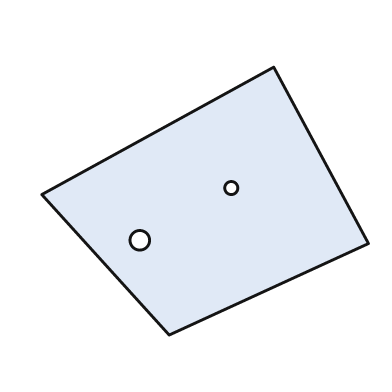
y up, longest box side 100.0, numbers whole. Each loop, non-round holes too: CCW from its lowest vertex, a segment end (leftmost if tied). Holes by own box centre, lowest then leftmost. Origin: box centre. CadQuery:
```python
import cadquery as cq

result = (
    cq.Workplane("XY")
    .moveTo(-11.0, -41.0)
    .lineTo(50.0, -13.0)
    .lineTo(21.0, 41.0)
    .lineTo(-50.0, 2.0)
    .close()
    .moveTo(-20.0, -12.0)
    .circle(3.0)
    .moveTo(8.0, 4.0)
    .circle(2.0)
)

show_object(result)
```